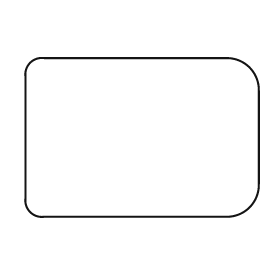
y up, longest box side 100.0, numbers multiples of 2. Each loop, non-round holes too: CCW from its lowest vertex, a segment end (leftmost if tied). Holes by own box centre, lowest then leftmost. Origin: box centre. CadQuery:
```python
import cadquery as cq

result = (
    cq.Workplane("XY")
    .moveTo(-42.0, -34.0)
    .lineTo(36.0, -34.0)
    .threePointArc((46.0, -30.0), (50.0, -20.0))
    .lineTo(50.0, 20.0)
    .threePointArc((46.0, 30.0), (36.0, 34.0))
    .lineTo(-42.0, 34.0)
    .threePointArc((-48.0, 32.0), (-50.0, 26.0))
    .lineTo(-50.0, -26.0)
    .threePointArc((-48.0, -32.0), (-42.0, -34.0))
    .close()
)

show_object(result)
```